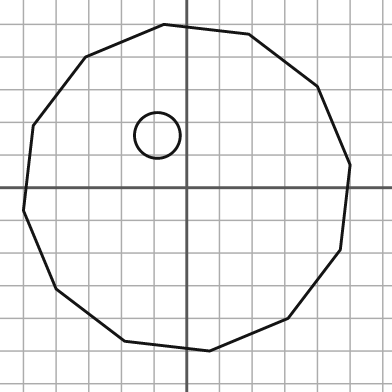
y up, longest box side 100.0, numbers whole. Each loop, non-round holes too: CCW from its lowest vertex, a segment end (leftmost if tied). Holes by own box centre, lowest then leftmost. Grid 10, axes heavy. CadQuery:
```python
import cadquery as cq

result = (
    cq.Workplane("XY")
    .moveTo(7.0, -50.0)
    .lineTo(31.0, -40.0)
    .lineTo(47.0, -19.0)
    .lineTo(50.0, 7.0)
    .lineTo(40.0, 31.0)
    .lineTo(19.0, 47.0)
    .lineTo(-7.0, 50.0)
    .lineTo(-31.0, 40.0)
    .lineTo(-47.0, 19.0)
    .lineTo(-50.0, -7.0)
    .lineTo(-40.0, -31.0)
    .lineTo(-19.0, -47.0)
    .close()
    .moveTo(-9.0, 16.0)
    .circle(7.0)
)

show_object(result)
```